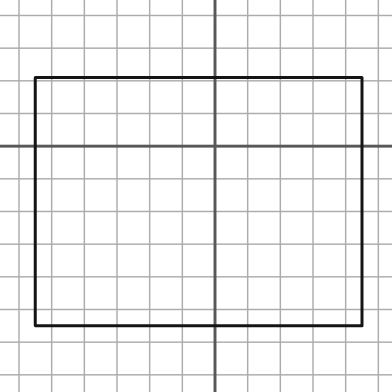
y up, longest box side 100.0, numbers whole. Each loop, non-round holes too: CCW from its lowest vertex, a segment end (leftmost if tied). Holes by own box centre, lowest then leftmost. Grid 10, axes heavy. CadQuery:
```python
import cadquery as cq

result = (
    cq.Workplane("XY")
    .moveTo(-55.0, -55.0)
    .lineTo(45.0, -55.0)
    .lineTo(45.0, 21.0)
    .lineTo(-55.0, 21.0)
    .close()
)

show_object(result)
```